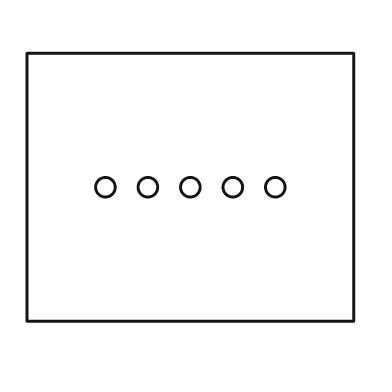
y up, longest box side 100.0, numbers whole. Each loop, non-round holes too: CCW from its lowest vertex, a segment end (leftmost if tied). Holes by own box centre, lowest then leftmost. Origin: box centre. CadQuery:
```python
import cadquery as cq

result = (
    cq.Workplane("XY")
    .moveTo(-50.0, -41.0)
    .lineTo(50.0, -41.0)
    .lineTo(50.0, 41.0)
    .lineTo(-50.0, 41.0)
    .close()
    .moveTo(-26.0, 0.0)
    .circle(3.0)
    .moveTo(-13.0, 0.0)
    .circle(3.0)
    .moveTo(0.0, 0.0)
    .circle(3.0)
    .moveTo(13.0, 0.0)
    .circle(3.0)
    .moveTo(26.0, 0.0)
    .circle(3.0)
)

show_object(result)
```